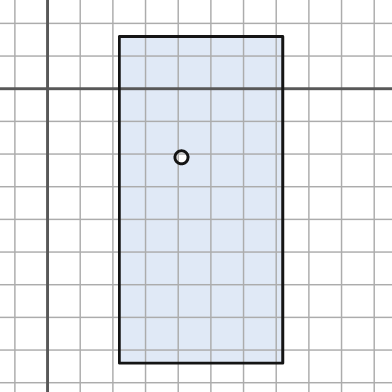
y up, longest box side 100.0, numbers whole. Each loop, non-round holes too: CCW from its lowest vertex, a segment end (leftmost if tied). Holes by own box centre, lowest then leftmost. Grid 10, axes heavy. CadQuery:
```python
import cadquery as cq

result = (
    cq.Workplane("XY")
    .moveTo(22.0, -84.0)
    .lineTo(72.0, -84.0)
    .lineTo(72.0, 16.0)
    .lineTo(22.0, 16.0)
    .close()
    .moveTo(41.0, -21.0)
    .circle(2.0)
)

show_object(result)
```